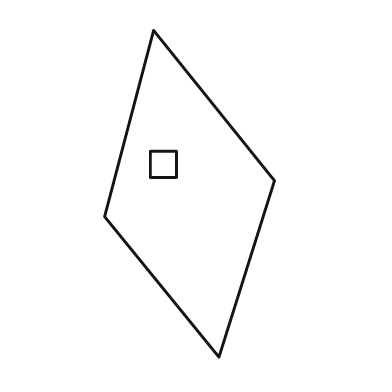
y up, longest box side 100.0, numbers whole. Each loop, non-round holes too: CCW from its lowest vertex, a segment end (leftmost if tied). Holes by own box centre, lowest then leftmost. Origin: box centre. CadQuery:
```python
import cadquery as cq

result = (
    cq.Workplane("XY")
    .moveTo(9.0, -50.0)
    .lineTo(26.0, 4.0)
    .lineTo(-11.0, 50.0)
    .lineTo(-26.0, -7.0)
    .close()
    .moveTo(-12.0, 5.0)
    .lineTo(-4.0, 5.0)
    .lineTo(-4.0, 13.0)
    .lineTo(-12.0, 13.0)
    .close()
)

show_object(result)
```